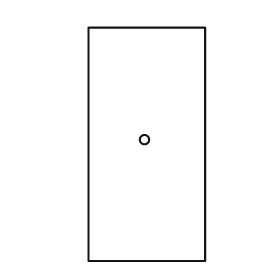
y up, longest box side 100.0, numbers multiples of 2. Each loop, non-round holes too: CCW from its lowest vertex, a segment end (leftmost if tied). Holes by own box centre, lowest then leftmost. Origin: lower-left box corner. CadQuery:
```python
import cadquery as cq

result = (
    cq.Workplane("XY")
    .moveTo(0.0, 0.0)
    .lineTo(50.0, 0.0)
    .lineTo(50.0, 100.0)
    .lineTo(0.0, 100.0)
    .close()
    .moveTo(24.0, 52.0)
    .circle(2.0)
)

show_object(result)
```